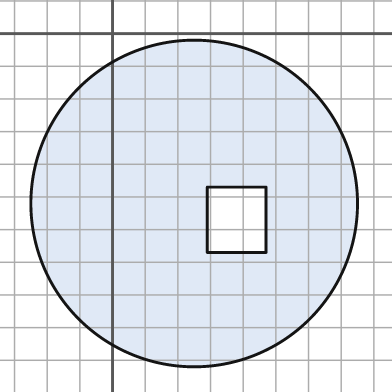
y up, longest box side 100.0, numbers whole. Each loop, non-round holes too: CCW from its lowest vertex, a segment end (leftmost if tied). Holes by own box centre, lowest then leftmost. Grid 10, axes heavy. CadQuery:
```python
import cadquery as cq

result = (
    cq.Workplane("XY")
    .moveTo(25.0, -52.0)
    .circle(50.0)
    .moveTo(29.0, -67.0)
    .lineTo(47.0, -67.0)
    .lineTo(47.0, -47.0)
    .lineTo(29.0, -47.0)
    .close()
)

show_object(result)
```